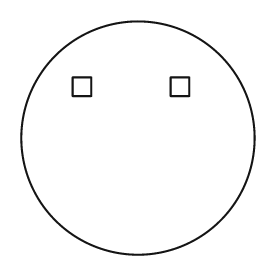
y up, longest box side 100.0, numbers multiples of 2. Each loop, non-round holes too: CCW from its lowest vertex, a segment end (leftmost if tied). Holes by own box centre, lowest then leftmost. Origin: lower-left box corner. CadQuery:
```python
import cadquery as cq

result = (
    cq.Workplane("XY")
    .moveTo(50.0, 50.0)
    .circle(50.0)
    .moveTo(22.0, 68.0)
    .lineTo(30.0, 68.0)
    .lineTo(30.0, 76.0)
    .lineTo(22.0, 76.0)
    .close()
    .moveTo(64.0, 68.0)
    .lineTo(72.0, 68.0)
    .lineTo(72.0, 76.0)
    .lineTo(64.0, 76.0)
    .close()
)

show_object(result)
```